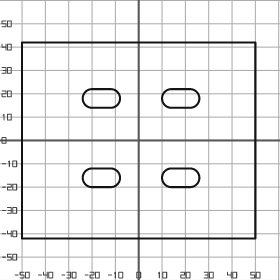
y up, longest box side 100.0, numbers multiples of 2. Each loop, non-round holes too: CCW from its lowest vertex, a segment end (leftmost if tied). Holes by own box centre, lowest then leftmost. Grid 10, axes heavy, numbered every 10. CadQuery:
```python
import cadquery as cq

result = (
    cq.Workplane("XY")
    .moveTo(-50.0, -42.0)
    .lineTo(50.0, -42.0)
    .lineTo(50.0, 42.0)
    .lineTo(-50.0, 42.0)
    .close()
    .moveTo(-20.0, -20.0)
    .lineTo(-12.0, -20.0)
    .threePointArc((-8.0, -16.0), (-12.0, -12.0))
    .lineTo(-20.0, -12.0)
    .threePointArc((-24.0, -16.0), (-20.0, -20.0))
    .close()
    .moveTo(14.0, -20.0)
    .lineTo(22.0, -20.0)
    .threePointArc((26.0, -16.0), (22.0, -12.0))
    .lineTo(14.0, -12.0)
    .threePointArc((10.0, -16.0), (14.0, -20.0))
    .close()
    .moveTo(-20.0, 14.0)
    .lineTo(-12.0, 14.0)
    .threePointArc((-8.0, 18.0), (-12.0, 22.0))
    .lineTo(-20.0, 22.0)
    .threePointArc((-24.0, 18.0), (-20.0, 14.0))
    .close()
    .moveTo(14.0, 14.0)
    .lineTo(22.0, 14.0)
    .threePointArc((26.0, 18.0), (22.0, 22.0))
    .lineTo(14.0, 22.0)
    .threePointArc((10.0, 18.0), (14.0, 14.0))
    .close()
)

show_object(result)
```